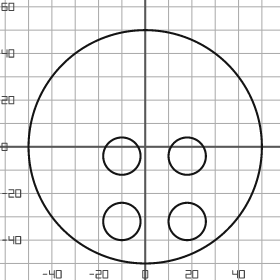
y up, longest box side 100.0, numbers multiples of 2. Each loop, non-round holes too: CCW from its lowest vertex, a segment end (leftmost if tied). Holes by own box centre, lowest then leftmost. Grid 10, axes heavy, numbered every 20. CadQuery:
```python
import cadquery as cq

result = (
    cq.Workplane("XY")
    .moveTo(0.0, 0.0)
    .circle(50.0)
    .moveTo(-10.0, -32.0)
    .circle(8.0)
    .moveTo(18.0, -32.0)
    .circle(8.0)
    .moveTo(-10.0, -4.0)
    .circle(8.0)
    .moveTo(18.0, -4.0)
    .circle(8.0)
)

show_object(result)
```